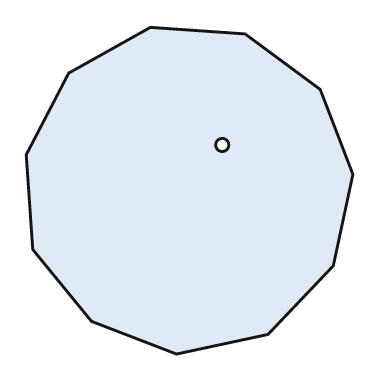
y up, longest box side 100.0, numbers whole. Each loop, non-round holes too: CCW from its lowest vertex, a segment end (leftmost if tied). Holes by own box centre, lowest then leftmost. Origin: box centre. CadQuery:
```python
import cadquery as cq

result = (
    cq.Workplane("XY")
    .moveTo(-4.0, -50.0)
    .lineTo(24.0, -44.0)
    .lineTo(44.0, -23.0)
    .lineTo(50.0, 5.0)
    .lineTo(40.0, 31.0)
    .lineTo(17.0, 48.0)
    .lineTo(-12.0, 50.0)
    .lineTo(-37.0, 36.0)
    .lineTo(-50.0, 11.0)
    .lineTo(-48.0, -18.0)
    .lineTo(-30.0, -40.0)
    .close()
    .moveTo(10.0, 14.0)
    .circle(2.0)
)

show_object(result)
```